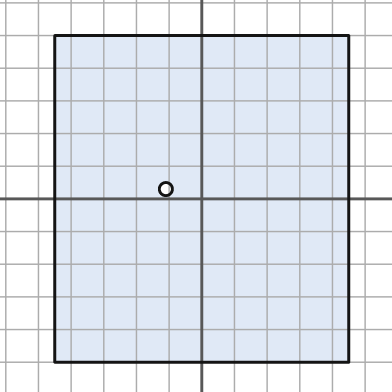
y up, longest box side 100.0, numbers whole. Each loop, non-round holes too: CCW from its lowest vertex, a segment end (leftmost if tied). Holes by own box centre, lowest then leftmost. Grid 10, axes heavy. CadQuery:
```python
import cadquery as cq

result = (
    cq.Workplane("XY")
    .moveTo(-45.0, -50.0)
    .lineTo(45.0, -50.0)
    .lineTo(45.0, 50.0)
    .lineTo(-45.0, 50.0)
    .close()
    .moveTo(-11.0, 3.0)
    .circle(2.0)
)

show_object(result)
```